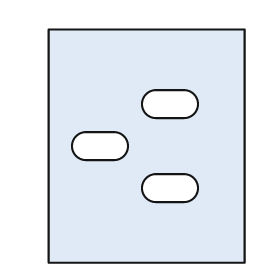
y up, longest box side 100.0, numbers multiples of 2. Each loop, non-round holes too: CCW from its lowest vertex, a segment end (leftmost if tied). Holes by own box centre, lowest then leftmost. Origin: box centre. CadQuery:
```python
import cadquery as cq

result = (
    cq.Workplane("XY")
    .moveTo(-42.0, -50.0)
    .lineTo(42.0, -50.0)
    .lineTo(42.0, 50.0)
    .lineTo(-42.0, 50.0)
    .close()
    .moveTo(4.0, -24.0)
    .lineTo(16.0, -24.0)
    .threePointArc((22.0, -18.0), (16.0, -12.0))
    .lineTo(4.0, -12.0)
    .threePointArc((-2.0, -18.0), (4.0, -24.0))
    .close()
    .moveTo(-26.0, -6.0)
    .lineTo(-14.0, -6.0)
    .threePointArc((-8.0, 0.0), (-14.0, 6.0))
    .lineTo(-26.0, 6.0)
    .threePointArc((-32.0, 0.0), (-26.0, -6.0))
    .close()
    .moveTo(4.0, 12.0)
    .lineTo(16.0, 12.0)
    .threePointArc((22.0, 18.0), (16.0, 24.0))
    .lineTo(4.0, 24.0)
    .threePointArc((-2.0, 18.0), (4.0, 12.0))
    .close()
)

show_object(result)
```